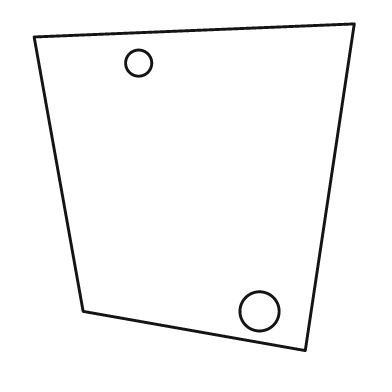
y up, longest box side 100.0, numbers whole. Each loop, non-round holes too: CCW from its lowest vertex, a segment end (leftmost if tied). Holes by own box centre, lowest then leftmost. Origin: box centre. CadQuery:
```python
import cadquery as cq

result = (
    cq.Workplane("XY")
    .moveTo(34.0, -50.0)
    .lineTo(49.0, 50.0)
    .lineTo(-49.0, 46.0)
    .lineTo(-34.0, -38.0)
    .close()
    .moveTo(20.0, -38.0)
    .circle(6.0)
    .moveTo(-17.0, 38.0)
    .circle(4.0)
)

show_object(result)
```